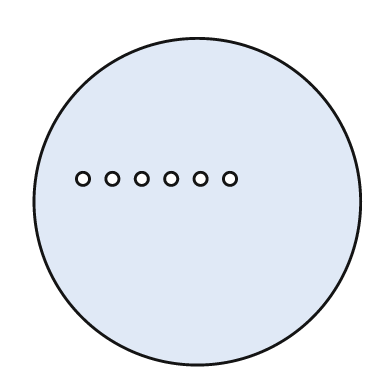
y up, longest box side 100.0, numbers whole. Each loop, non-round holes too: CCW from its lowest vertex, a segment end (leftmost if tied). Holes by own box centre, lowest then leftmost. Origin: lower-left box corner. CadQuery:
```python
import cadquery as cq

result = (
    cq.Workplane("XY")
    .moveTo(50.0, 50.0)
    .circle(50.0)
    .moveTo(15.0, 57.0)
    .circle(2.0)
    .moveTo(24.0, 57.0)
    .circle(2.0)
    .moveTo(33.0, 57.0)
    .circle(2.0)
    .moveTo(42.0, 57.0)
    .circle(2.0)
    .moveTo(51.0, 57.0)
    .circle(2.0)
    .moveTo(60.0, 57.0)
    .circle(2.0)
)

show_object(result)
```